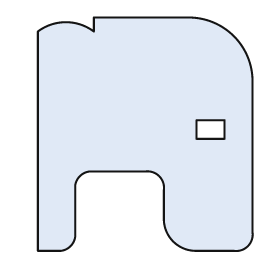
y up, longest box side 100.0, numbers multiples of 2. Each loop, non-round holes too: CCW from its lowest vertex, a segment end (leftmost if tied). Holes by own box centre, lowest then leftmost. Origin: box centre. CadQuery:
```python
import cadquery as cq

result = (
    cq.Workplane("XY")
    .moveTo(-46.0, -50.0)
    .lineTo(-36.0, -50.0)
    .threePointArc((-32.0, -48.0), (-30.0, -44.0))
    .lineTo(-30.0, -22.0)
    .threePointArc((-28.0, -18.0), (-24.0, -16.0))
    .lineTo(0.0, -16.0)
    .threePointArc((6.0, -18.0), (8.0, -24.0))
    .lineTo(8.0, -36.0)
    .threePointArc((12.0, -46.0), (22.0, -50.0))
    .lineTo(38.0, -50.0)
    .threePointArc((44.0, -48.0), (46.0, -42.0))
    .lineTo(46.0, 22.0)
    .threePointArc((38.0, 42.0), (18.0, 50.0))
    .lineTo(-22.0, 50.0)
    .lineTo(-22.0, 44.0)
    .threePointArc((-34.0, 48.0), (-46.0, 44.0))
    .close()
    .moveTo(22.0, -2.0)
    .lineTo(34.0, -2.0)
    .lineTo(34.0, 6.0)
    .lineTo(22.0, 6.0)
    .close()
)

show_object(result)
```